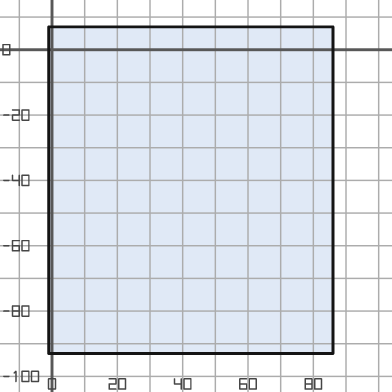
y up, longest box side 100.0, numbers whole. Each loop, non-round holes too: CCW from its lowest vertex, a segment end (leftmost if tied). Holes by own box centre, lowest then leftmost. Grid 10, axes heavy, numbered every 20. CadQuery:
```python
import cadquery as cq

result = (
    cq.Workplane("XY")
    .moveTo(-1.0, -93.0)
    .lineTo(86.0, -93.0)
    .lineTo(86.0, 7.0)
    .lineTo(-1.0, 7.0)
    .close()
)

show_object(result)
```